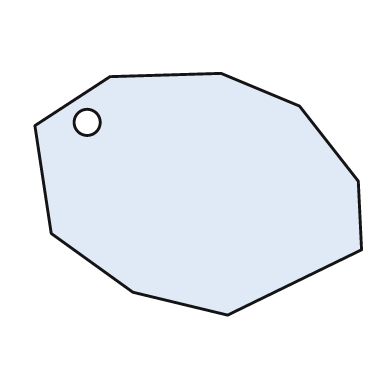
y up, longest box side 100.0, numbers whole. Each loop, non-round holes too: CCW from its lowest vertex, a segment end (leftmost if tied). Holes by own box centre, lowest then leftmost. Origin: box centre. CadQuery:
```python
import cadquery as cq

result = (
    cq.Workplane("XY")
    .moveTo(9.0, -37.0)
    .lineTo(50.0, -17.0)
    .lineTo(49.0, 4.0)
    .lineTo(31.0, 27.0)
    .lineTo(7.0, 37.0)
    .lineTo(-27.0, 36.0)
    .lineTo(-50.0, 21.0)
    .lineTo(-45.0, -12.0)
    .lineTo(-20.0, -30.0)
    .close()
    .moveTo(-34.0, 22.0)
    .circle(4.0)
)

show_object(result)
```